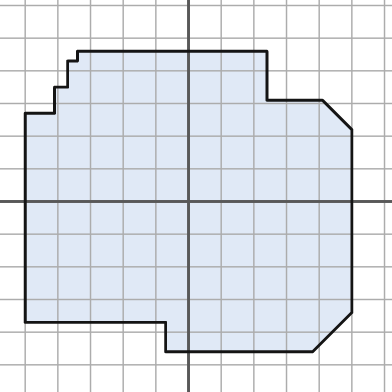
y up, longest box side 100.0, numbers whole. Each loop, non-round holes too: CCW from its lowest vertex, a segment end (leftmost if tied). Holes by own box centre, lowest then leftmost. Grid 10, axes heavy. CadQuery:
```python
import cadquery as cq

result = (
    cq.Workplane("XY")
    .moveTo(-7.0, -46.0)
    .lineTo(38.0, -46.0)
    .lineTo(50.0, -34.0)
    .lineTo(50.0, 22.0)
    .lineTo(41.0, 31.0)
    .lineTo(24.0, 31.0)
    .lineTo(24.0, 46.0)
    .lineTo(-34.0, 46.0)
    .lineTo(-34.0, 43.0)
    .lineTo(-37.0, 43.0)
    .lineTo(-37.0, 35.0)
    .lineTo(-41.0, 35.0)
    .lineTo(-41.0, 27.0)
    .lineTo(-50.0, 27.0)
    .lineTo(-50.0, -37.0)
    .lineTo(-7.0, -37.0)
    .close()
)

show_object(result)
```